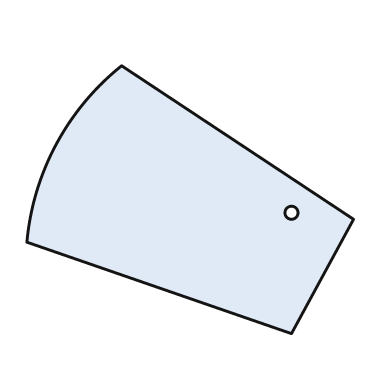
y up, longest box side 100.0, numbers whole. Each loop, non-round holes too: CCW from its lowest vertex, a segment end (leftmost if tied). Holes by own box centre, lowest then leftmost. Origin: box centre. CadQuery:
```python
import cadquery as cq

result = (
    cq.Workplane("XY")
    .moveTo(31.0, -41.0)
    .lineTo(50.0, -6.0)
    .lineTo(-21.0, 41.0)
    .threePointArc((-41.0, 17.0), (-50.0, -13.0))
    .close()
    .moveTo(31.0, -4.0)
    .circle(2.0)
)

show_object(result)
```